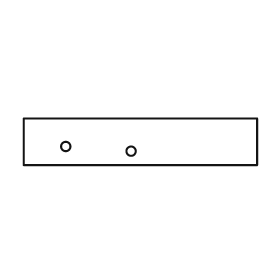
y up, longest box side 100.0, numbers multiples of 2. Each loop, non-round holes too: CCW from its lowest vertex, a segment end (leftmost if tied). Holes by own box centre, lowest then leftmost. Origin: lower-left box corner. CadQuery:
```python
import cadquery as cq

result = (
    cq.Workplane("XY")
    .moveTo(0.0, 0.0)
    .lineTo(100.0, 0.0)
    .lineTo(100.0, 20.0)
    .lineTo(0.0, 20.0)
    .close()
    .moveTo(46.0, 6.0)
    .circle(2.0)
    .moveTo(18.0, 8.0)
    .circle(2.0)
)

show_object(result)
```